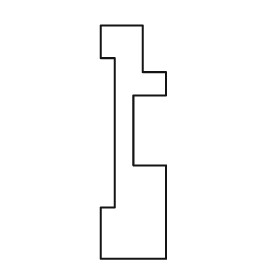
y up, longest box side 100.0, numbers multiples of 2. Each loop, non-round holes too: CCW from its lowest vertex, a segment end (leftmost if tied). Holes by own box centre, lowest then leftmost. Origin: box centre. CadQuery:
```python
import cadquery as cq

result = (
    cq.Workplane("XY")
    .moveTo(-14.0, -50.0)
    .lineTo(14.0, -50.0)
    .lineTo(14.0, -10.0)
    .lineTo(0.0, -10.0)
    .lineTo(0.0, 20.0)
    .lineTo(14.0, 20.0)
    .lineTo(14.0, 30.0)
    .lineTo(4.0, 30.0)
    .lineTo(4.0, 50.0)
    .lineTo(-14.0, 50.0)
    .lineTo(-14.0, 36.0)
    .lineTo(-8.0, 36.0)
    .lineTo(-8.0, -28.0)
    .lineTo(-14.0, -28.0)
    .close()
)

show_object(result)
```